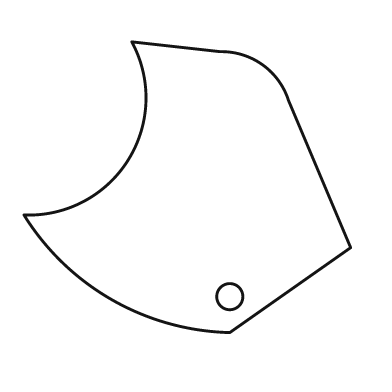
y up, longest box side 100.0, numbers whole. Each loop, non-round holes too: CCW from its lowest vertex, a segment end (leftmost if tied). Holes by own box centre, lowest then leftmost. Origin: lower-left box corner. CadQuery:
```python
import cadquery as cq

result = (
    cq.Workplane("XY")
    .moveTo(63.0, 0.0)
    .lineTo(100.0, 26.0)
    .lineTo(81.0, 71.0)
    .threePointArc((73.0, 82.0), (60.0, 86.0))
    .lineTo(33.0, 89.0)
    .threePointArc((32.0, 53.0), (0.0, 36.0))
    .threePointArc((27.0, 10.0), (63.0, 0.0))
    .close()
    .moveTo(63.0, 11.0)
    .circle(4.0)
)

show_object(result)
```